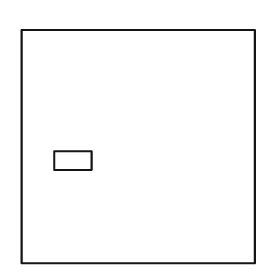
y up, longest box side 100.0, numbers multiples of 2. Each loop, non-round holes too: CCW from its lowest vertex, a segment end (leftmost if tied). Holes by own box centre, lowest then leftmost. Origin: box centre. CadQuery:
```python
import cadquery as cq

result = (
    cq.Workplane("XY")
    .moveTo(-50.0, -50.0)
    .lineTo(50.0, -50.0)
    .lineTo(50.0, 50.0)
    .lineTo(-50.0, 50.0)
    .close()
    .moveTo(-36.0, -10.0)
    .lineTo(-20.0, -10.0)
    .lineTo(-20.0, -2.0)
    .lineTo(-36.0, -2.0)
    .close()
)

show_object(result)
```